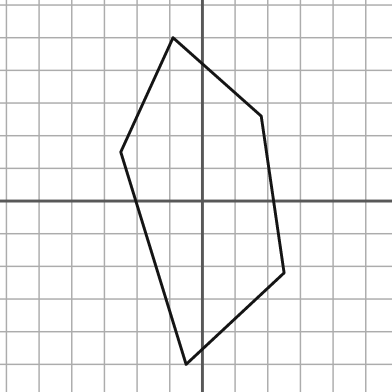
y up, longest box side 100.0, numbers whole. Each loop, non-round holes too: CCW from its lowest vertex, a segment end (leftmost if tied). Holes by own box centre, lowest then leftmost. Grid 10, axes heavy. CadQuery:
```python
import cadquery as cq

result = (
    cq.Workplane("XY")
    .moveTo(-5.0, -50.0)
    .lineTo(25.0, -22.0)
    .lineTo(18.0, 26.0)
    .lineTo(-9.0, 50.0)
    .lineTo(-25.0, 15.0)
    .close()
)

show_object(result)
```